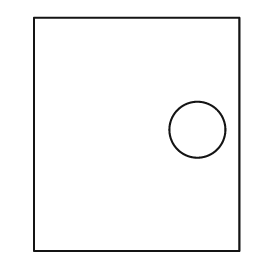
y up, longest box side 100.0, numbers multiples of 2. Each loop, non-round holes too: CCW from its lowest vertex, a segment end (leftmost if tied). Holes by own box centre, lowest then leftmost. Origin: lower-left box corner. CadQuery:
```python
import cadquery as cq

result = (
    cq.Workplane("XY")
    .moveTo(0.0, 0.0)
    .lineTo(88.0, 0.0)
    .lineTo(88.0, 100.0)
    .lineTo(0.0, 100.0)
    .close()
    .moveTo(70.0, 52.0)
    .circle(12.0)
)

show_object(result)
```